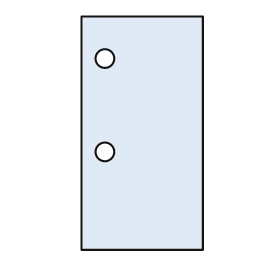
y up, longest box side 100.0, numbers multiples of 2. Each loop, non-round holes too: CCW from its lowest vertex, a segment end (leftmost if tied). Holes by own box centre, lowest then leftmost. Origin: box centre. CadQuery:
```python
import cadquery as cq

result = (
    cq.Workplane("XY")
    .moveTo(-26.0, -50.0)
    .lineTo(26.0, -50.0)
    .lineTo(26.0, 50.0)
    .lineTo(-26.0, 50.0)
    .close()
    .moveTo(-16.0, -8.0)
    .circle(4.0)
    .moveTo(-16.0, 32.0)
    .circle(4.0)
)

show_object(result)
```